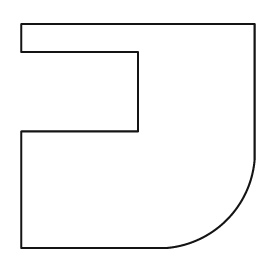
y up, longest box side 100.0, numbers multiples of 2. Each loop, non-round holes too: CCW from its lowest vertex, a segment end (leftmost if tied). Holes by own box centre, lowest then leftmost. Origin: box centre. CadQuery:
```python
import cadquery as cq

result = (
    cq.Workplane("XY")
    .moveTo(-50.0, -48.0)
    .lineTo(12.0, -48.0)
    .threePointArc((38.0, -36.0), (50.0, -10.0))
    .lineTo(50.0, 48.0)
    .lineTo(-50.0, 48.0)
    .lineTo(-50.0, 36.0)
    .lineTo(0.0, 36.0)
    .lineTo(0.0, 2.0)
    .lineTo(-50.0, 2.0)
    .close()
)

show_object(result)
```